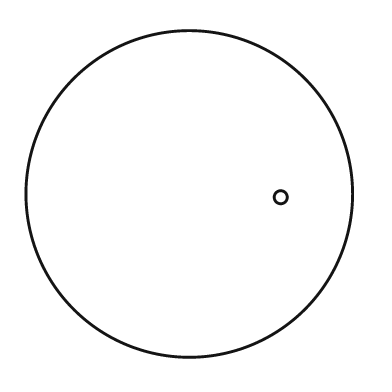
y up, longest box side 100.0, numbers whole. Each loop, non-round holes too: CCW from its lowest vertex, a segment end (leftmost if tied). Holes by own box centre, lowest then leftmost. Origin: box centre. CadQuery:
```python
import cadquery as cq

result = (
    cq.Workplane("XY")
    .moveTo(0.0, 0.0)
    .circle(50.0)
    .moveTo(28.0, -1.0)
    .circle(2.0)
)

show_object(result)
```